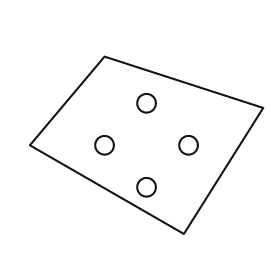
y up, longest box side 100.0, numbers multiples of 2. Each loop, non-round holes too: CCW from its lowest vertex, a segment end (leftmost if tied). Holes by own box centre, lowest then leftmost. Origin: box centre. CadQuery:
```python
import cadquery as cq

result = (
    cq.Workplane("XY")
    .moveTo(16.0, -38.0)
    .lineTo(50.0, 16.0)
    .lineTo(-18.0, 38.0)
    .lineTo(-50.0, 0.0)
    .close()
    .moveTo(0.0, -18.0)
    .circle(4.0)
    .moveTo(-18.0, 0.0)
    .circle(4.0)
    .moveTo(18.0, 0.0)
    .circle(4.0)
    .moveTo(0.0, 18.0)
    .circle(4.0)
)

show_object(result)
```